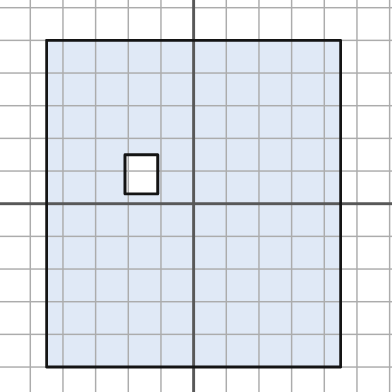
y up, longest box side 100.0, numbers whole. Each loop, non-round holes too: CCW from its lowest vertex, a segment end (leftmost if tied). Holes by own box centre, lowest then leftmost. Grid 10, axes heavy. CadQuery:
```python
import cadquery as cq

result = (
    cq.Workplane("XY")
    .moveTo(-45.0, -50.0)
    .lineTo(45.0, -50.0)
    .lineTo(45.0, 50.0)
    .lineTo(-45.0, 50.0)
    .close()
    .moveTo(-21.0, 3.0)
    .lineTo(-11.0, 3.0)
    .lineTo(-11.0, 15.0)
    .lineTo(-21.0, 15.0)
    .close()
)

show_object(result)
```